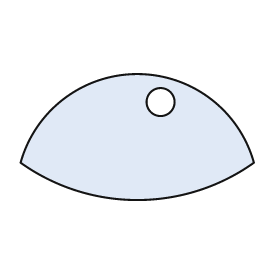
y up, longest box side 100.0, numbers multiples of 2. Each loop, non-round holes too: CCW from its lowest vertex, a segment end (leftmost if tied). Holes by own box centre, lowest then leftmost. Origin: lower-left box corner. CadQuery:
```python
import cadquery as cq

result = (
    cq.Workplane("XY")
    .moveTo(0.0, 16.0)
    .threePointArc((50.0, 0.0), (100.0, 16.0))
    .threePointArc((50.0, 54.0), (0.0, 16.0))
    .close()
    .moveTo(60.0, 42.0)
    .circle(6.0)
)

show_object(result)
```